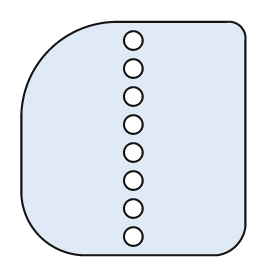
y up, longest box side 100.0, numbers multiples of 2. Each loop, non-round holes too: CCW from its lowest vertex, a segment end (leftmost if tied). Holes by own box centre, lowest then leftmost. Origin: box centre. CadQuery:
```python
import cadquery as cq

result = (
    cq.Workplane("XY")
    .moveTo(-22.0, -50.0)
    .lineTo(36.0, -50.0)
    .threePointArc((44.0, -46.0), (48.0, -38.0))
    .lineTo(48.0, 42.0)
    .threePointArc((46.0, 48.0), (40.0, 50.0))
    .lineTo(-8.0, 50.0)
    .threePointArc((-36.0, 38.0), (-48.0, 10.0))
    .lineTo(-48.0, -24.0)
    .threePointArc((-40.0, -42.0), (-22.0, -50.0))
    .close()
    .moveTo(0.0, -42.0)
    .circle(4.0)
    .moveTo(0.0, -30.0)
    .circle(4.0)
    .moveTo(0.0, -18.0)
    .circle(4.0)
    .moveTo(0.0, -6.0)
    .circle(4.0)
    .moveTo(0.0, 6.0)
    .circle(4.0)
    .moveTo(0.0, 18.0)
    .circle(4.0)
    .moveTo(0.0, 30.0)
    .circle(4.0)
    .moveTo(0.0, 42.0)
    .circle(4.0)
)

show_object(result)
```